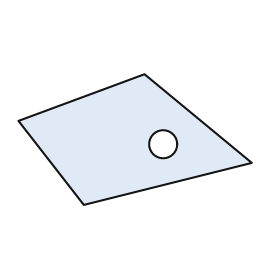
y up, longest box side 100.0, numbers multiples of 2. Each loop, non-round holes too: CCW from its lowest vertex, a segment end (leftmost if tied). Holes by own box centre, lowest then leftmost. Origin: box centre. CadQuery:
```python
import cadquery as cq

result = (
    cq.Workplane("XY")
    .moveTo(-22.0, -28.0)
    .lineTo(50.0, -10.0)
    .lineTo(4.0, 28.0)
    .lineTo(-50.0, 8.0)
    .close()
    .moveTo(12.0, -2.0)
    .circle(6.0)
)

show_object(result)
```